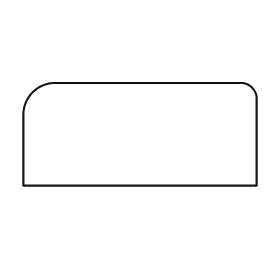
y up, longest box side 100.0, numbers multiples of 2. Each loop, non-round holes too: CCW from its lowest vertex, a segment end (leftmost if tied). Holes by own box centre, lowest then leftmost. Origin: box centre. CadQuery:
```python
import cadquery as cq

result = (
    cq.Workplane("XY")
    .moveTo(-50.0, -22.0)
    .lineTo(50.0, -22.0)
    .lineTo(50.0, 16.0)
    .threePointArc((48.0, 20.0), (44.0, 22.0))
    .lineTo(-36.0, 22.0)
    .threePointArc((-46.0, 18.0), (-50.0, 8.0))
    .close()
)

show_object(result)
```